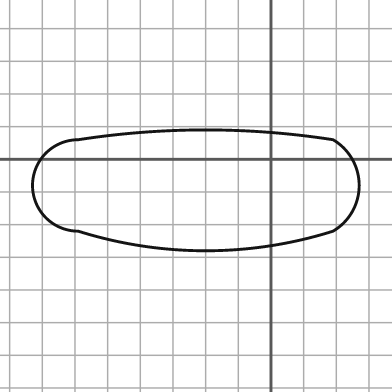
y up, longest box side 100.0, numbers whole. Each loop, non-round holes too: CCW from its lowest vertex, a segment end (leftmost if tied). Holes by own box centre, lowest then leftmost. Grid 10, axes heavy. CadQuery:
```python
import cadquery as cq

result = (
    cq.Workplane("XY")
    .moveTo(-59.0, -22.0)
    .threePointArc((-20.0, -28.0), (19.0, -22.0))
    .threePointArc((27.0, -8.0), (19.0, 6.0))
    .threePointArc((-20.0, 9.0), (-59.0, 6.0))
    .threePointArc((-73.0, -8.0), (-59.0, -22.0))
    .close()
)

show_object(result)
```